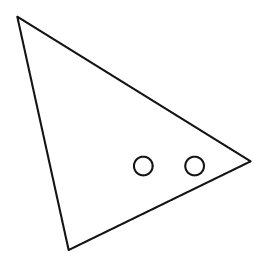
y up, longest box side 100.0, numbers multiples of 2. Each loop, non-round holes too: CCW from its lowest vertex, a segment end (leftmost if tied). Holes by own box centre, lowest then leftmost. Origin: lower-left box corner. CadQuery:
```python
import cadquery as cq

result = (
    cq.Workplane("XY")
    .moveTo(22.0, 0.0)
    .lineTo(100.0, 38.0)
    .lineTo(0.0, 100.0)
    .close()
    .moveTo(54.0, 36.0)
    .circle(4.0)
    .moveTo(76.0, 36.0)
    .circle(4.0)
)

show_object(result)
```